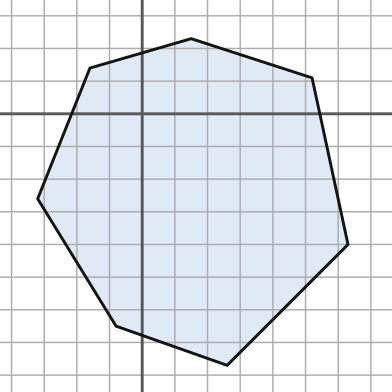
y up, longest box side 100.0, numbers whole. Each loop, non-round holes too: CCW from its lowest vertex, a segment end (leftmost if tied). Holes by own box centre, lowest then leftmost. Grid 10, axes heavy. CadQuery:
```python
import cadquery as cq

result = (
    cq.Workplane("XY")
    .moveTo(26.0, -77.0)
    .lineTo(63.0, -40.0)
    .lineTo(52.0, 11.0)
    .lineTo(15.0, 23.0)
    .lineTo(-16.0, 14.0)
    .lineTo(-32.0, -26.0)
    .lineTo(-8.0, -65.0)
    .close()
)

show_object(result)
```